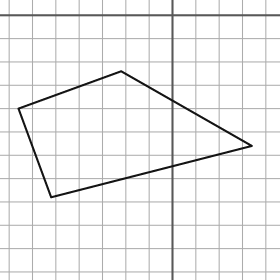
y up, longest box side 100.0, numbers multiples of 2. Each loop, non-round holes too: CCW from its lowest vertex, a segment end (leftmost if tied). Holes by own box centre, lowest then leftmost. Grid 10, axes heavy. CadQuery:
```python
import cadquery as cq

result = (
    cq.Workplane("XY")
    .moveTo(-52.0, -78.0)
    .lineTo(34.0, -56.0)
    .lineTo(-22.0, -24.0)
    .lineTo(-66.0, -40.0)
    .close()
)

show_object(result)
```